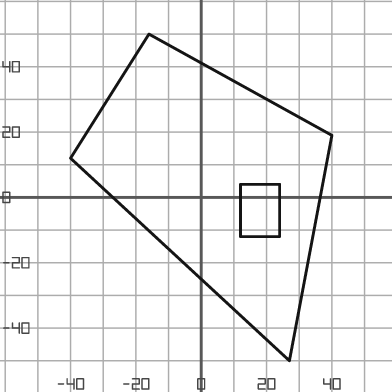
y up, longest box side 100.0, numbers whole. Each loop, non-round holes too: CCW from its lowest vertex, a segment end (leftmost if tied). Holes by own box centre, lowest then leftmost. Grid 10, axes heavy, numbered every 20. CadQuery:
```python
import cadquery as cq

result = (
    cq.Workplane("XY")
    .moveTo(27.0, -50.0)
    .lineTo(40.0, 19.0)
    .lineTo(-16.0, 50.0)
    .lineTo(-40.0, 12.0)
    .close()
    .moveTo(12.0, -12.0)
    .lineTo(24.0, -12.0)
    .lineTo(24.0, 4.0)
    .lineTo(12.0, 4.0)
    .close()
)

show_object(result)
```